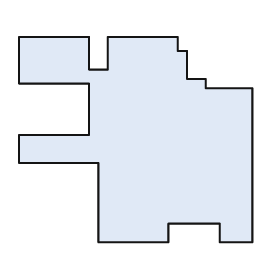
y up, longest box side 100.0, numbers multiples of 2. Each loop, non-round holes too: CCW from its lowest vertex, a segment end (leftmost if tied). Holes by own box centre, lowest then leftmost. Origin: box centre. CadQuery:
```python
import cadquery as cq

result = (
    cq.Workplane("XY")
    .moveTo(-16.0, -44.0)
    .lineTo(14.0, -44.0)
    .lineTo(14.0, -36.0)
    .lineTo(36.0, -36.0)
    .lineTo(36.0, -44.0)
    .lineTo(50.0, -44.0)
    .lineTo(50.0, 22.0)
    .lineTo(30.0, 22.0)
    .lineTo(30.0, 26.0)
    .lineTo(22.0, 26.0)
    .lineTo(22.0, 38.0)
    .lineTo(18.0, 38.0)
    .lineTo(18.0, 44.0)
    .lineTo(-12.0, 44.0)
    .lineTo(-12.0, 30.0)
    .lineTo(-20.0, 30.0)
    .lineTo(-20.0, 44.0)
    .lineTo(-50.0, 44.0)
    .lineTo(-50.0, 24.0)
    .lineTo(-20.0, 24.0)
    .lineTo(-20.0, 2.0)
    .lineTo(-50.0, 2.0)
    .lineTo(-50.0, -10.0)
    .lineTo(-16.0, -10.0)
    .close()
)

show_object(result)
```